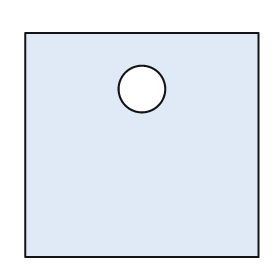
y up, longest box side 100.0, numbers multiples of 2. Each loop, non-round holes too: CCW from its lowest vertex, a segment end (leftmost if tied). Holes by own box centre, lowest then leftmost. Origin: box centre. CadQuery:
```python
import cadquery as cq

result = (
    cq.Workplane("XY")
    .moveTo(-50.0, -48.0)
    .lineTo(50.0, -48.0)
    .lineTo(50.0, 48.0)
    .lineTo(-50.0, 48.0)
    .close()
    .moveTo(0.0, 24.0)
    .circle(10.0)
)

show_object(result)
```